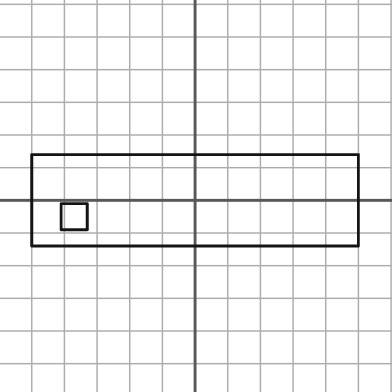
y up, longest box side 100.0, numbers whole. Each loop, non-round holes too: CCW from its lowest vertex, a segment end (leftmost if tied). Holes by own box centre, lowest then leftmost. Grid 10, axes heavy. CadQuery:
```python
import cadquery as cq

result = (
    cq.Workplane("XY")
    .moveTo(-50.0, -14.0)
    .lineTo(50.0, -14.0)
    .lineTo(50.0, 14.0)
    .lineTo(-50.0, 14.0)
    .close()
    .moveTo(-41.0, -9.0)
    .lineTo(-33.0, -9.0)
    .lineTo(-33.0, -1.0)
    .lineTo(-41.0, -1.0)
    .close()
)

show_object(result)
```